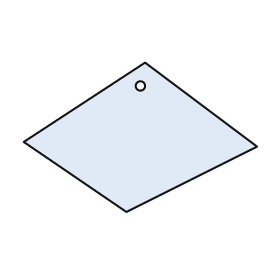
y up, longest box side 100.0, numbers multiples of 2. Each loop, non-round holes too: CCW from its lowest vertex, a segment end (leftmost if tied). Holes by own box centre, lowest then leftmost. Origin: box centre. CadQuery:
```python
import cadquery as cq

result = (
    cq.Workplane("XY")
    .moveTo(-6.0, -32.0)
    .lineTo(50.0, -4.0)
    .lineTo(2.0, 32.0)
    .lineTo(-50.0, -2.0)
    .close()
    .moveTo(0.0, 22.0)
    .circle(2.0)
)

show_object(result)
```